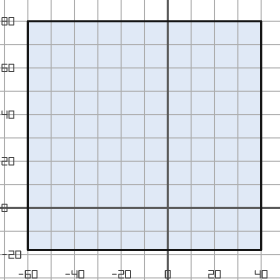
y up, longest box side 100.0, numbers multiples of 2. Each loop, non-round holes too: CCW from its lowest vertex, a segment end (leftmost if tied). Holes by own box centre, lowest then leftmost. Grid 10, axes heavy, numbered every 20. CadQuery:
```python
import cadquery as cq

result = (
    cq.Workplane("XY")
    .moveTo(-60.0, -18.0)
    .lineTo(40.0, -18.0)
    .lineTo(40.0, 80.0)
    .lineTo(-60.0, 80.0)
    .close()
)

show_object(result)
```